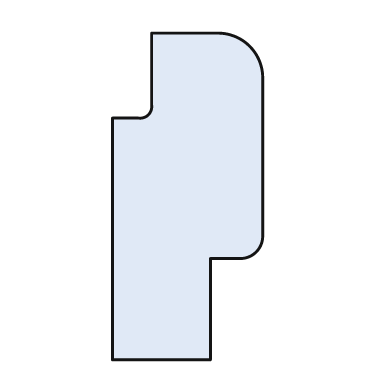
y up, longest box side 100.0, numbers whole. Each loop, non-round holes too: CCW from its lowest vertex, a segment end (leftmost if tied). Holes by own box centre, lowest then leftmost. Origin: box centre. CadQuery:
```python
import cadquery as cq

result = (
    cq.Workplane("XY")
    .moveTo(-23.0, -50.0)
    .lineTo(7.0, -50.0)
    .lineTo(7.0, -19.0)
    .lineTo(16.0, -19.0)
    .threePointArc((21.0, -17.0), (23.0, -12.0))
    .lineTo(23.0, 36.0)
    .threePointArc((19.0, 46.0), (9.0, 50.0))
    .lineTo(-11.0, 50.0)
    .lineTo(-11.0, 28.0)
    .threePointArc((-12.0, 25.0), (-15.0, 24.0))
    .lineTo(-23.0, 24.0)
    .close()
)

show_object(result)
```